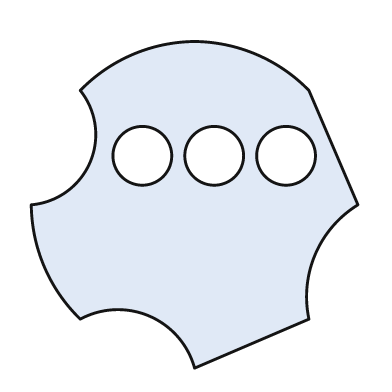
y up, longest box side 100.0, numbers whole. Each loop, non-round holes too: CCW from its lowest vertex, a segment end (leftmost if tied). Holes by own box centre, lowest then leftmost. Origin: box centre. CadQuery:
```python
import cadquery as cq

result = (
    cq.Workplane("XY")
    .moveTo(0.0, -50.0)
    .lineTo(35.0, -35.0)
    .threePointArc((37.0, -15.0), (50.0, 0.0))
    .lineTo(35.0, 35.0)
    .threePointArc((19.0, 46.0), (0.0, 50.0))
    .threePointArc((-19.0, 46.0), (-35.0, 35.0))
    .threePointArc((-32.0, 13.0), (-50.0, 0.0))
    .threePointArc((-46.0, -19.0), (-35.0, -35.0))
    .threePointArc((-14.0, -34.0), (0.0, -50.0))
    .close()
    .moveTo(-16.0, 15.0)
    .circle(9.0)
    .moveTo(6.0, 15.0)
    .circle(9.0)
    .moveTo(28.0, 15.0)
    .circle(9.0)
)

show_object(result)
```